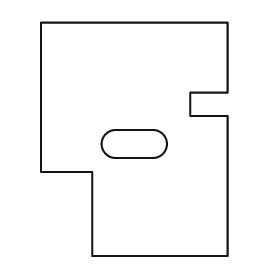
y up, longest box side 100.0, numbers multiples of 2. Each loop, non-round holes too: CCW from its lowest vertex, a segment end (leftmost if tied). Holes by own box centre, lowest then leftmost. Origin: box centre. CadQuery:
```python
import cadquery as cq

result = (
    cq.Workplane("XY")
    .moveTo(-18.0, -50.0)
    .lineTo(40.0, -50.0)
    .lineTo(40.0, 10.0)
    .lineTo(24.0, 10.0)
    .lineTo(24.0, 20.0)
    .lineTo(40.0, 20.0)
    .lineTo(40.0, 50.0)
    .lineTo(-40.0, 50.0)
    .lineTo(-40.0, -14.0)
    .lineTo(-18.0, -14.0)
    .close()
    .moveTo(-8.0, -8.0)
    .lineTo(8.0, -8.0)
    .threePointArc((14.0, -2.0), (8.0, 4.0))
    .lineTo(-8.0, 4.0)
    .threePointArc((-14.0, -2.0), (-8.0, -8.0))
    .close()
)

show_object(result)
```